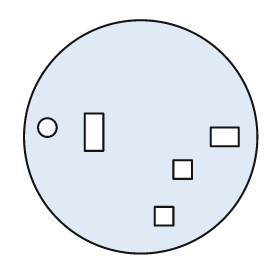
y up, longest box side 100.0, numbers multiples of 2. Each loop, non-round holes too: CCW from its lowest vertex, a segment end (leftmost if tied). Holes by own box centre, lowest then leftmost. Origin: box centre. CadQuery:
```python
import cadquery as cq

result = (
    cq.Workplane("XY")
    .moveTo(0.0, 0.0)
    .circle(50.0)
    .moveTo(6.0, -38.0)
    .lineTo(14.0, -38.0)
    .lineTo(14.0, -30.0)
    .lineTo(6.0, -30.0)
    .close()
    .moveTo(14.0, -18.0)
    .lineTo(22.0, -18.0)
    .lineTo(22.0, -10.0)
    .lineTo(14.0, -10.0)
    .close()
    .moveTo(30.0, -4.0)
    .lineTo(42.0, -4.0)
    .lineTo(42.0, 4.0)
    .lineTo(30.0, 4.0)
    .close()
    .moveTo(-24.0, -6.0)
    .lineTo(-16.0, -6.0)
    .lineTo(-16.0, 10.0)
    .lineTo(-24.0, 10.0)
    .close()
    .moveTo(-40.0, 4.0)
    .circle(4.0)
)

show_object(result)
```